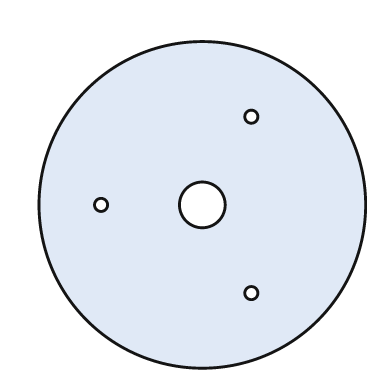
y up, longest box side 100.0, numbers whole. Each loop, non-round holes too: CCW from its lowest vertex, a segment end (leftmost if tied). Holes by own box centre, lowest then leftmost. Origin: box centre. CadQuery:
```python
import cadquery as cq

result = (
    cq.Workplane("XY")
    .moveTo(0.0, 0.0)
    .circle(50.0)
    .moveTo(15.0, -27.0)
    .circle(2.0)
    .moveTo(-31.0, 0.0)
    .circle(2.0)
    .moveTo(0.0, 0.0)
    .circle(7.0)
    .moveTo(15.0, 27.0)
    .circle(2.0)
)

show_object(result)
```